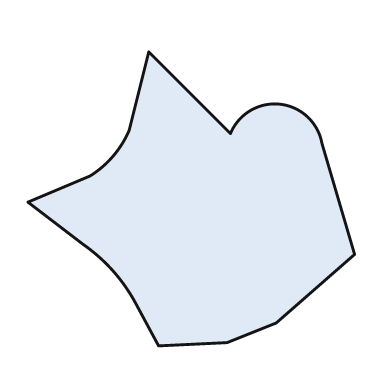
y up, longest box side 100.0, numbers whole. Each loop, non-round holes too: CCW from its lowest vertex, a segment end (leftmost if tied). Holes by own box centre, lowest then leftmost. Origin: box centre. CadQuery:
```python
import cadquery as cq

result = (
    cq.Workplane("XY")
    .moveTo(-10.0, -45.0)
    .lineTo(11.0, -44.0)
    .lineTo(26.0, -38.0)
    .lineTo(50.0, -17.0)
    .lineTo(40.0, 17.0)
    .threePointArc((27.0, 29.0), (12.0, 20.0))
    .lineTo(-13.0, 45.0)
    .lineTo(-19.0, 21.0)
    .threePointArc((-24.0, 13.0), (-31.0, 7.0))
    .lineTo(-50.0, -1.0)
    .lineTo(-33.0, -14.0)
    .threePointArc((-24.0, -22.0), (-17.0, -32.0))
    .close()
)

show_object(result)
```